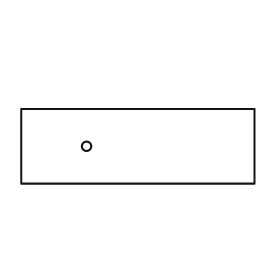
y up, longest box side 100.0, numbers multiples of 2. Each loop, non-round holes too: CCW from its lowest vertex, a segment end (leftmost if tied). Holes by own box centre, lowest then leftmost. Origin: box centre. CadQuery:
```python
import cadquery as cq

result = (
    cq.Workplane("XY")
    .moveTo(-50.0, -16.0)
    .lineTo(50.0, -16.0)
    .lineTo(50.0, 16.0)
    .lineTo(-50.0, 16.0)
    .close()
    .moveTo(-22.0, 0.0)
    .circle(2.0)
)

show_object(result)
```